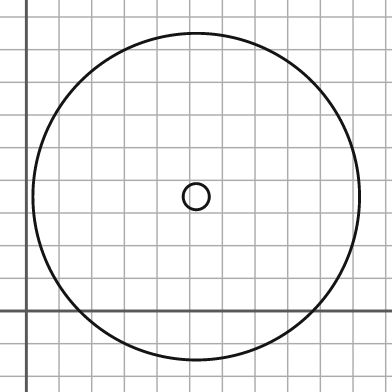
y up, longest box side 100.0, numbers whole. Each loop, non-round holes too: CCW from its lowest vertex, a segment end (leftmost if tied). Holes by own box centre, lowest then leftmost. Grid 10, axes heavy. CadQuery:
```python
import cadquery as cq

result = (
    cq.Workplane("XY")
    .moveTo(52.0, 35.0)
    .circle(50.0)
    .moveTo(52.0, 35.0)
    .circle(4.0)
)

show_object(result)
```